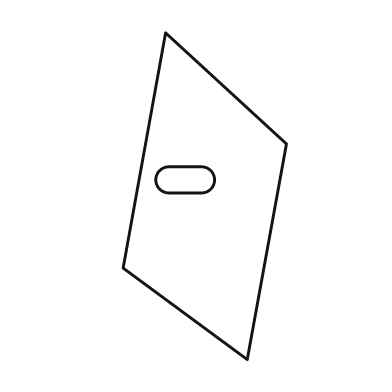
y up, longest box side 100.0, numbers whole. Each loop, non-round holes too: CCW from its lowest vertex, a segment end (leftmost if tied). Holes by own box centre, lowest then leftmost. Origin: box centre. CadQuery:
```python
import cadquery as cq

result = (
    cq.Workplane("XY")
    .moveTo(13.0, -50.0)
    .lineTo(25.0, 16.0)
    .lineTo(-12.0, 50.0)
    .lineTo(-25.0, -22.0)
    .close()
    .moveTo(-11.0, 1.0)
    .lineTo(-1.0, 1.0)
    .threePointArc((3.0, 5.0), (-1.0, 9.0))
    .lineTo(-11.0, 9.0)
    .threePointArc((-15.0, 5.0), (-11.0, 1.0))
    .close()
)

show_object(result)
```